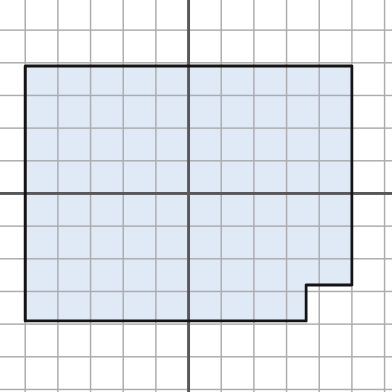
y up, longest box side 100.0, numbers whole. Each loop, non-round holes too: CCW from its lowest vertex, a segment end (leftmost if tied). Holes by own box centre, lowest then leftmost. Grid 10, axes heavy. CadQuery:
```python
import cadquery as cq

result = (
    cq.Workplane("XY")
    .moveTo(-50.0, -39.0)
    .lineTo(36.0, -39.0)
    .lineTo(36.0, -28.0)
    .lineTo(50.0, -28.0)
    .lineTo(50.0, 39.0)
    .lineTo(-50.0, 39.0)
    .close()
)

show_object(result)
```